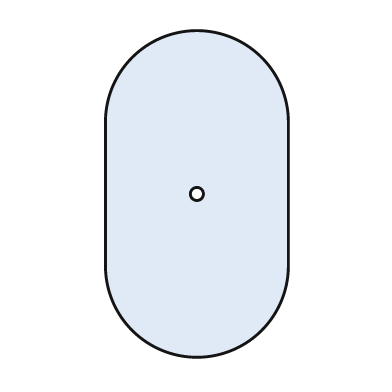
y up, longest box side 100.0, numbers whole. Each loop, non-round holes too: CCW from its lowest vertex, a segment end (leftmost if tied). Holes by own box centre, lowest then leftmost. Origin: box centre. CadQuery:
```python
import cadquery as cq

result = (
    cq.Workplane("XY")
    .moveTo(-28.0, -22.0)
    .threePointArc((0.0, -50.0), (28.0, -22.0))
    .lineTo(28.0, 22.0)
    .threePointArc((0.0, 50.0), (-28.0, 22.0))
    .close()
    .moveTo(0.0, 0.0)
    .circle(2.0)
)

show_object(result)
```